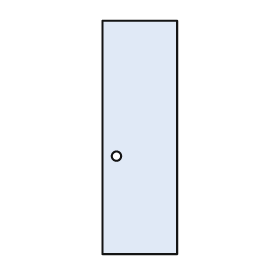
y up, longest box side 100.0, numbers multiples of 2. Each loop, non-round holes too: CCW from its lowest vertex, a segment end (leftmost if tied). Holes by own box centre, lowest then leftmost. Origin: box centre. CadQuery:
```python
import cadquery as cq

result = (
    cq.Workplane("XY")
    .moveTo(-16.0, -50.0)
    .lineTo(16.0, -50.0)
    .lineTo(16.0, 50.0)
    .lineTo(-16.0, 50.0)
    .close()
    .moveTo(-10.0, -8.0)
    .circle(2.0)
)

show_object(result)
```